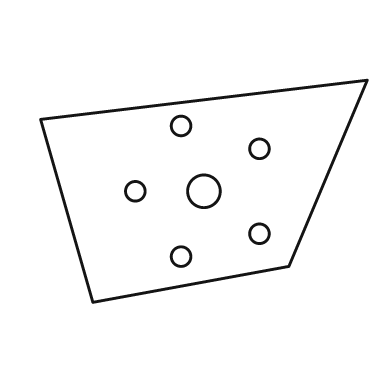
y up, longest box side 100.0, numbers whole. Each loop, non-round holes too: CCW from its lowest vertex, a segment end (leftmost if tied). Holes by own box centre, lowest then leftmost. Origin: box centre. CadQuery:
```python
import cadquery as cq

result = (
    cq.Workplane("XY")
    .moveTo(-34.0, -34.0)
    .lineTo(26.0, -23.0)
    .lineTo(50.0, 34.0)
    .lineTo(-50.0, 22.0)
    .close()
    .moveTo(-7.0, -20.0)
    .circle(3.0)
    .moveTo(17.0, -13.0)
    .circle(3.0)
    .moveTo(-21.0, 0.0)
    .circle(3.0)
    .moveTo(0.0, 0.0)
    .circle(5.0)
    .moveTo(17.0, 13.0)
    .circle(3.0)
    .moveTo(-7.0, 20.0)
    .circle(3.0)
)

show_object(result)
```